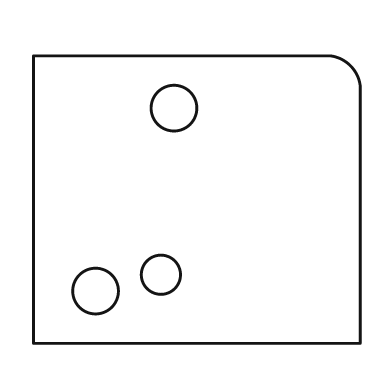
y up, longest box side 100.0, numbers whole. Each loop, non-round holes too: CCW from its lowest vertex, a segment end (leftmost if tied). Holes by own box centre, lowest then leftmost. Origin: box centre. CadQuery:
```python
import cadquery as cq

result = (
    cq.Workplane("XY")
    .moveTo(-50.0, -44.0)
    .lineTo(50.0, -44.0)
    .lineTo(50.0, 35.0)
    .threePointArc((47.0, 41.0), (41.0, 44.0))
    .lineTo(-50.0, 44.0)
    .close()
    .moveTo(-31.0, -28.0)
    .circle(7.0)
    .moveTo(-11.0, -23.0)
    .circle(6.0)
    .moveTo(-7.0, 28.0)
    .circle(7.0)
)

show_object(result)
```